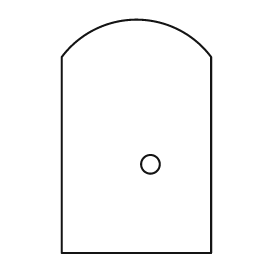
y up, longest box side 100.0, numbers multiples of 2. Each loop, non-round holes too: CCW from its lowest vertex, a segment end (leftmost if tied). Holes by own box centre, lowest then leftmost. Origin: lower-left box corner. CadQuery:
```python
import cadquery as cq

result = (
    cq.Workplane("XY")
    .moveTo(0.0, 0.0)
    .lineTo(64.0, 0.0)
    .lineTo(64.0, 84.0)
    .threePointArc((32.0, 100.0), (0.0, 84.0))
    .close()
    .moveTo(38.0, 38.0)
    .circle(4.0)
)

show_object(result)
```